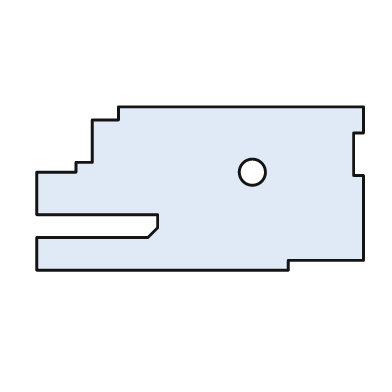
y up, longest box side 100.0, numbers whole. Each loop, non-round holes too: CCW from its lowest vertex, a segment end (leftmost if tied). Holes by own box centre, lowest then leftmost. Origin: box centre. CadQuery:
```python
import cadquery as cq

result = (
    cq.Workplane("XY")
    .moveTo(-50.0, -25.0)
    .lineTo(27.0, -25.0)
    .lineTo(27.0, -22.0)
    .lineTo(50.0, -22.0)
    .lineTo(50.0, 4.0)
    .lineTo(47.0, 4.0)
    .lineTo(47.0, 17.0)
    .lineTo(50.0, 17.0)
    .lineTo(50.0, 25.0)
    .lineTo(-25.0, 25.0)
    .lineTo(-25.0, 21.0)
    .lineTo(-33.0, 21.0)
    .lineTo(-33.0, 8.0)
    .lineTo(-38.0, 8.0)
    .lineTo(-38.0, 5.0)
    .lineTo(-50.0, 5.0)
    .lineTo(-50.0, -8.0)
    .lineTo(-13.0, -8.0)
    .lineTo(-13.0, -12.0)
    .lineTo(-16.0, -15.0)
    .lineTo(-50.0, -15.0)
    .close()
    .moveTo(16.0, 5.0)
    .circle(4.0)
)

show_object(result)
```